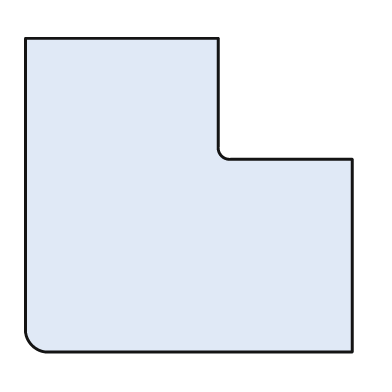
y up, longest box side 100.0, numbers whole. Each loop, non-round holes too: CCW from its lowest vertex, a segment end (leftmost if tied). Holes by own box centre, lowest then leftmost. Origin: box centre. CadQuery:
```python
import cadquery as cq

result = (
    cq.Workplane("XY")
    .moveTo(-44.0, -48.0)
    .lineTo(50.0, -48.0)
    .lineTo(50.0, 11.0)
    .lineTo(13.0, 11.0)
    .threePointArc((10.0, 12.0), (9.0, 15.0))
    .lineTo(9.0, 48.0)
    .lineTo(-50.0, 48.0)
    .lineTo(-50.0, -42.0)
    .threePointArc((-48.0, -46.0), (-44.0, -48.0))
    .close()
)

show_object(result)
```